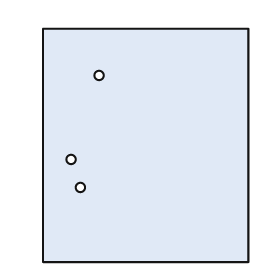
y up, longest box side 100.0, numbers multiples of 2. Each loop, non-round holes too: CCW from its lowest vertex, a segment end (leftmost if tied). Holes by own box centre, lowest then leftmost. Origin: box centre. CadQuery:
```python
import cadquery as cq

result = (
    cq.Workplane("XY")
    .moveTo(-44.0, -50.0)
    .lineTo(44.0, -50.0)
    .lineTo(44.0, 50.0)
    .lineTo(-44.0, 50.0)
    .close()
    .moveTo(-28.0, -18.0)
    .circle(2.0)
    .moveTo(-32.0, -6.0)
    .circle(2.0)
    .moveTo(-20.0, 30.0)
    .circle(2.0)
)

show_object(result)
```